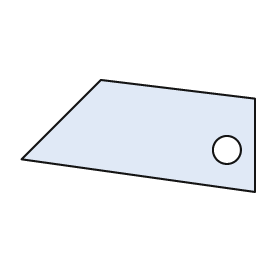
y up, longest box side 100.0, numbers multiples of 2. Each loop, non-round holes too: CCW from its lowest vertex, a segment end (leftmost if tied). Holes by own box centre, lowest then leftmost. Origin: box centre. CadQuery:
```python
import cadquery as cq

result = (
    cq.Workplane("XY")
    .moveTo(50.0, -24.0)
    .lineTo(50.0, 16.0)
    .lineTo(-16.0, 24.0)
    .lineTo(-50.0, -10.0)
    .close()
    .moveTo(38.0, -6.0)
    .circle(6.0)
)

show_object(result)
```